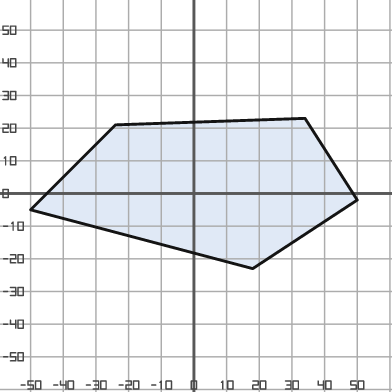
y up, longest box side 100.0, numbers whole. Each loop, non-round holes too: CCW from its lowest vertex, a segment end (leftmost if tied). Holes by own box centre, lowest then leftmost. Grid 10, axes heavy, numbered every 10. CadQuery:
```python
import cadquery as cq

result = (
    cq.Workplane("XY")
    .moveTo(18.0, -23.0)
    .lineTo(50.0, -2.0)
    .lineTo(34.0, 23.0)
    .lineTo(-24.0, 21.0)
    .lineTo(-50.0, -5.0)
    .close()
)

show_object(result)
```